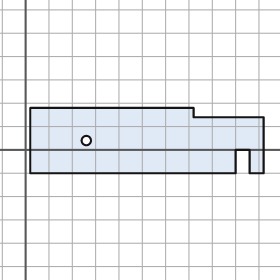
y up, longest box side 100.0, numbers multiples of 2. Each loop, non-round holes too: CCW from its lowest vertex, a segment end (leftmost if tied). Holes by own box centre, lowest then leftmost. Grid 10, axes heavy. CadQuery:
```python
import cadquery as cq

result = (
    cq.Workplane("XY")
    .moveTo(2.0, -10.0)
    .lineTo(90.0, -10.0)
    .lineTo(90.0, 0.0)
    .lineTo(96.0, 0.0)
    .lineTo(96.0, -10.0)
    .lineTo(102.0, -10.0)
    .lineTo(102.0, 14.0)
    .lineTo(72.0, 14.0)
    .lineTo(72.0, 18.0)
    .lineTo(2.0, 18.0)
    .close()
    .moveTo(26.0, 4.0)
    .circle(2.0)
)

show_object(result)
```